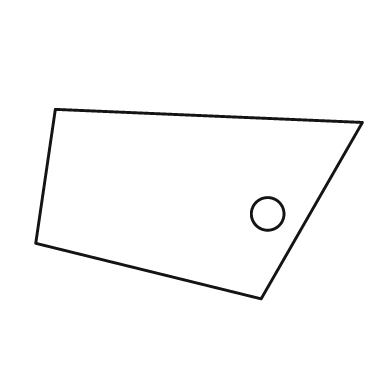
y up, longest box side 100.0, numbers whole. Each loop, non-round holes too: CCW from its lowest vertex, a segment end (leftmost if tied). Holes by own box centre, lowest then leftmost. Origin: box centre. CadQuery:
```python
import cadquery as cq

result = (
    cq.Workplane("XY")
    .moveTo(19.0, -29.0)
    .lineTo(50.0, 25.0)
    .lineTo(-44.0, 29.0)
    .lineTo(-50.0, -12.0)
    .close()
    .moveTo(21.0, -3.0)
    .circle(5.0)
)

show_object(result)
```